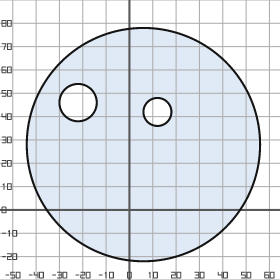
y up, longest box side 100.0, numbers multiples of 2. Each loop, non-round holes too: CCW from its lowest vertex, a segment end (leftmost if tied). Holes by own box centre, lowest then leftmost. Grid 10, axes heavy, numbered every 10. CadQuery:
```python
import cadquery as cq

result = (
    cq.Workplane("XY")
    .moveTo(6.0, 28.0)
    .circle(50.0)
    .moveTo(12.0, 42.0)
    .circle(6.0)
    .moveTo(-22.0, 46.0)
    .circle(8.0)
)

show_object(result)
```